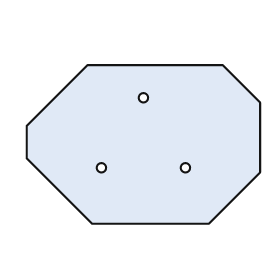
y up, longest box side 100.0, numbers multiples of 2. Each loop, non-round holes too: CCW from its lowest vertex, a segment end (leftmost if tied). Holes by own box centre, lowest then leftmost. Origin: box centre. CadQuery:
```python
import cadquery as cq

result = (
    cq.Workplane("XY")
    .moveTo(-22.0, -34.0)
    .lineTo(28.0, -34.0)
    .lineTo(50.0, -12.0)
    .lineTo(50.0, 18.0)
    .lineTo(34.0, 34.0)
    .lineTo(-24.0, 34.0)
    .lineTo(-50.0, 8.0)
    .lineTo(-50.0, -6.0)
    .close()
    .moveTo(-18.0, -10.0)
    .circle(2.0)
    .moveTo(18.0, -10.0)
    .circle(2.0)
    .moveTo(0.0, 20.0)
    .circle(2.0)
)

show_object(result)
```